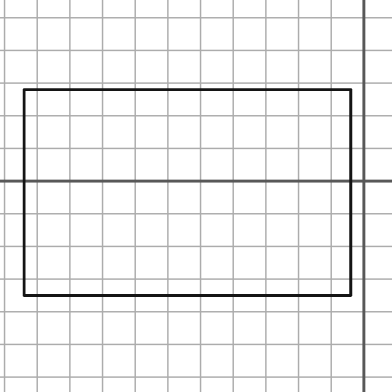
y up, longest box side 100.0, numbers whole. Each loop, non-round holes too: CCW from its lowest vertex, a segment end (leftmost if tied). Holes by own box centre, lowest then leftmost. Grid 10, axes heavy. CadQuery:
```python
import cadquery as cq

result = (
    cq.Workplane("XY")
    .moveTo(-104.0, -35.0)
    .lineTo(-4.0, -35.0)
    .lineTo(-4.0, 28.0)
    .lineTo(-104.0, 28.0)
    .close()
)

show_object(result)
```